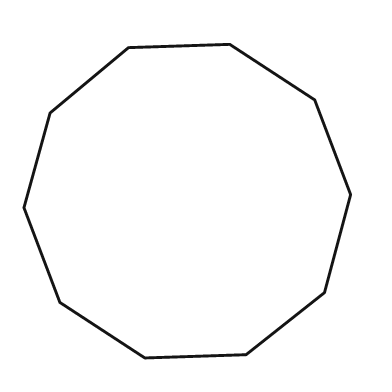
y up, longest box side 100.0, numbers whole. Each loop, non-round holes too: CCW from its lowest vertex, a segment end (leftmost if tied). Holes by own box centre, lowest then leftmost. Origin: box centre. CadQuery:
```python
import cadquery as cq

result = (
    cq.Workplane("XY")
    .moveTo(-13.0, -48.0)
    .lineTo(18.0, -47.0)
    .lineTo(42.0, -28.0)
    .lineTo(50.0, 2.0)
    .lineTo(39.0, 31.0)
    .lineTo(13.0, 48.0)
    .lineTo(-18.0, 47.0)
    .lineTo(-42.0, 27.0)
    .lineTo(-50.0, -2.0)
    .lineTo(-39.0, -31.0)
    .close()
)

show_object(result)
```